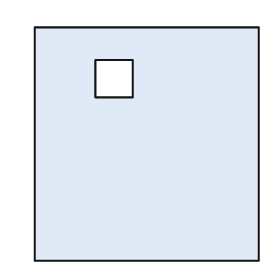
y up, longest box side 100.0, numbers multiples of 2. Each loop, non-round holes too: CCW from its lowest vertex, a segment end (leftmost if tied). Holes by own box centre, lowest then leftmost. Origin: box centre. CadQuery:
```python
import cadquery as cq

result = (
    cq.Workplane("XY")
    .moveTo(-48.0, -50.0)
    .lineTo(48.0, -50.0)
    .lineTo(48.0, 50.0)
    .lineTo(-48.0, 50.0)
    .close()
    .moveTo(-22.0, 20.0)
    .lineTo(-6.0, 20.0)
    .lineTo(-6.0, 36.0)
    .lineTo(-22.0, 36.0)
    .close()
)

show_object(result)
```